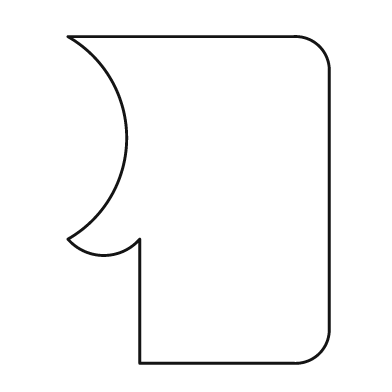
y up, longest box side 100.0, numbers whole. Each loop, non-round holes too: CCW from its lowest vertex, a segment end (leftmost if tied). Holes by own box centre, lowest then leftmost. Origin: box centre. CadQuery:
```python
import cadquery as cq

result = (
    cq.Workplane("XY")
    .moveTo(-18.0, -50.0)
    .lineTo(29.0, -50.0)
    .threePointArc((37.0, -47.0), (40.0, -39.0))
    .lineTo(40.0, 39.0)
    .threePointArc((37.0, 47.0), (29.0, 50.0))
    .lineTo(-40.0, 50.0)
    .threePointArc((-22.0, 19.0), (-40.0, -12.0))
    .threePointArc((-29.0, -17.0), (-18.0, -12.0))
    .close()
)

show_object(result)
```